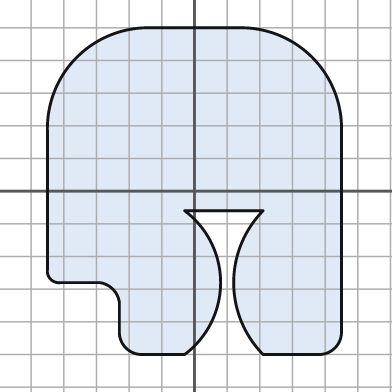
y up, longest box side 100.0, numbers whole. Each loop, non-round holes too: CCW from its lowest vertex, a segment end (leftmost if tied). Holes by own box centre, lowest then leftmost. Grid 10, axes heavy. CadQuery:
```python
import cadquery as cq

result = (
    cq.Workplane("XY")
    .moveTo(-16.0, -50.0)
    .lineTo(-3.0, -50.0)
    .threePointArc((8.0, -28.0), (-3.0, -6.0))
    .lineTo(21.0, -6.0)
    .threePointArc((12.0, -28.0), (21.0, -50.0))
    .lineTo(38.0, -50.0)
    .threePointArc((43.0, -48.0), (45.0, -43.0))
    .lineTo(45.0, 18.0)
    .threePointArc((36.0, 41.0), (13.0, 50.0))
    .lineTo(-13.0, 50.0)
    .threePointArc((-36.0, 41.0), (-45.0, 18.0))
    .lineTo(-45.0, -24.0)
    .threePointArc((-44.0, -27.0), (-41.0, -28.0))
    .lineTo(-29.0, -28.0)
    .threePointArc((-25.0, -30.0), (-23.0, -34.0))
    .lineTo(-23.0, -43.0)
    .threePointArc((-21.0, -48.0), (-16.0, -50.0))
    .close()
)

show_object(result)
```